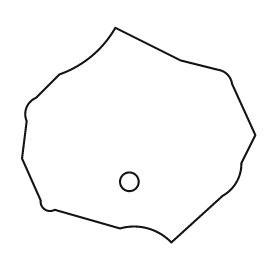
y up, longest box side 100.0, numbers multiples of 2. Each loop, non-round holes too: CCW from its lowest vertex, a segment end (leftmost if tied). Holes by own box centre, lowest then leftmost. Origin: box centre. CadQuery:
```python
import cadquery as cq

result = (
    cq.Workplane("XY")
    .moveTo(14.0, -46.0)
    .lineTo(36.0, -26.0)
    .threePointArc((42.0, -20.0), (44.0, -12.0))
    .lineTo(50.0, 0.0)
    .lineTo(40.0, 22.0)
    .threePointArc((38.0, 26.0), (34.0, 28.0))
    .lineTo(18.0, 32.0)
    .lineTo(-10.0, 46.0)
    .threePointArc((-20.0, 34.0), (-34.0, 26.0))
    .lineTo(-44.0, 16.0)
    .threePointArc((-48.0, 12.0), (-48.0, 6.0))
    .lineTo(-50.0, -10.0)
    .lineTo(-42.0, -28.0)
    .threePointArc((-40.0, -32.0), (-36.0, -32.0))
    .lineTo(-8.0, -40.0)
    .threePointArc((4.0, -40.0), (14.0, -46.0))
    .close()
    .moveTo(-4.0, -20.0)
    .circle(4.0)
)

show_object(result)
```